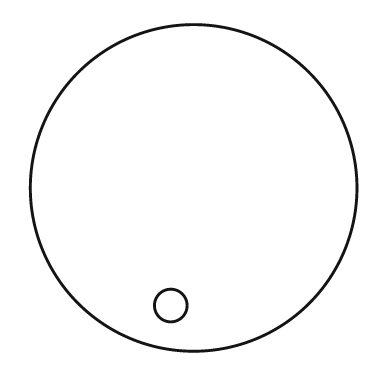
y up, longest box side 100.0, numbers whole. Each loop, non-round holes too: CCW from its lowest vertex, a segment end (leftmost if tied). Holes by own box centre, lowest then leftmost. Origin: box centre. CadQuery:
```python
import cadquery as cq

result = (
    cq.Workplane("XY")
    .moveTo(0.0, 0.0)
    .circle(50.0)
    .moveTo(-7.0, -36.0)
    .circle(5.0)
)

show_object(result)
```